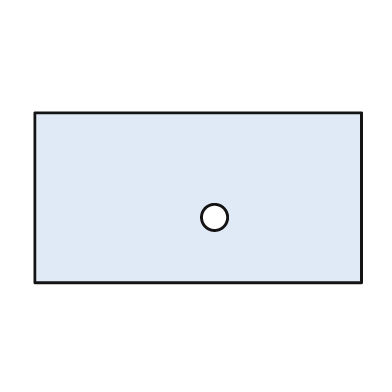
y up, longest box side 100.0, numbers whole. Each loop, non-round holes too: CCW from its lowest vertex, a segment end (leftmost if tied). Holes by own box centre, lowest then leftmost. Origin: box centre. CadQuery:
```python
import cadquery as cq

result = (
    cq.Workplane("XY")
    .moveTo(-50.0, -26.0)
    .lineTo(50.0, -26.0)
    .lineTo(50.0, 26.0)
    .lineTo(-50.0, 26.0)
    .close()
    .moveTo(5.0, -6.0)
    .circle(4.0)
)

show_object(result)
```